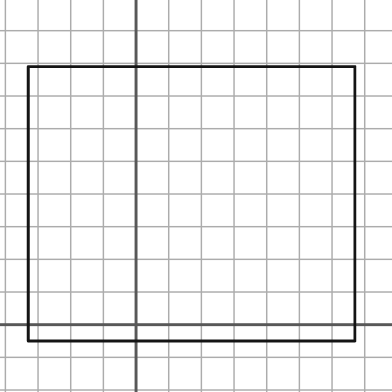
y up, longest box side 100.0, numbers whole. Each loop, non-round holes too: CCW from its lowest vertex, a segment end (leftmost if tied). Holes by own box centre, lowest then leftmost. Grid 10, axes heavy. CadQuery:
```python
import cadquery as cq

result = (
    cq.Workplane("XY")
    .moveTo(-33.0, -5.0)
    .lineTo(67.0, -5.0)
    .lineTo(67.0, 79.0)
    .lineTo(-33.0, 79.0)
    .close()
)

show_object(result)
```